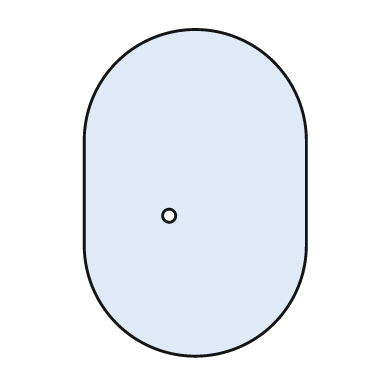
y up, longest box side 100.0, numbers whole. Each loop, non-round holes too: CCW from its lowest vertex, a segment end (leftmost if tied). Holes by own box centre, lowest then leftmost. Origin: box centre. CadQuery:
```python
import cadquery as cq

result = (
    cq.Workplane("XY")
    .moveTo(-34.0, -16.0)
    .threePointArc((0.0, -50.0), (34.0, -16.0))
    .lineTo(34.0, 16.0)
    .threePointArc((0.0, 50.0), (-34.0, 16.0))
    .close()
    .moveTo(-8.0, -7.0)
    .circle(2.0)
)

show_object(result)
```